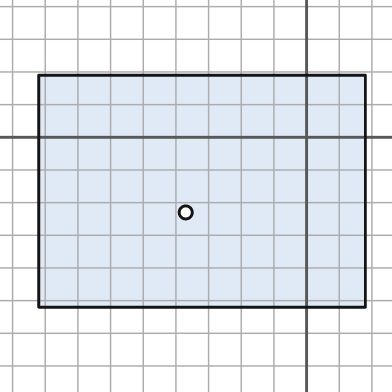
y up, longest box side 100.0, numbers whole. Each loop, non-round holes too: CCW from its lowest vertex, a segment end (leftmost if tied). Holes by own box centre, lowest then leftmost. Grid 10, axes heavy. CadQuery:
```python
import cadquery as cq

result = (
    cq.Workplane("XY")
    .moveTo(-82.0, -52.0)
    .lineTo(18.0, -52.0)
    .lineTo(18.0, 19.0)
    .lineTo(-82.0, 19.0)
    .close()
    .moveTo(-37.0, -23.0)
    .circle(2.0)
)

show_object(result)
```